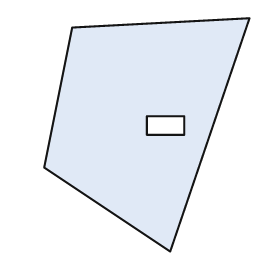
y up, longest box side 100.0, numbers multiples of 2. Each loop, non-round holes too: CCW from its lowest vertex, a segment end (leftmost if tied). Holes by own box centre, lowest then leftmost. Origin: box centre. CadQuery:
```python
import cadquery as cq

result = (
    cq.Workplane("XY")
    .moveTo(10.0, -50.0)
    .lineTo(44.0, 50.0)
    .lineTo(-32.0, 46.0)
    .lineTo(-44.0, -14.0)
    .close()
    .moveTo(0.0, 0.0)
    .lineTo(16.0, 0.0)
    .lineTo(16.0, 8.0)
    .lineTo(0.0, 8.0)
    .close()
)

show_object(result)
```